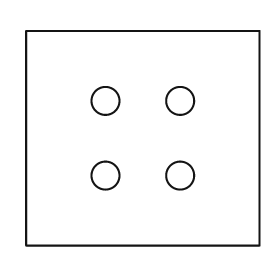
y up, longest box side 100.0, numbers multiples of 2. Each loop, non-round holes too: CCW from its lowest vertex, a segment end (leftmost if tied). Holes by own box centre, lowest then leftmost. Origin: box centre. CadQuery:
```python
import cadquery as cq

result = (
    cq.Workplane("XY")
    .moveTo(-50.0, -46.0)
    .lineTo(50.0, -46.0)
    .lineTo(50.0, 46.0)
    .lineTo(-50.0, 46.0)
    .close()
    .moveTo(-16.0, -16.0)
    .circle(6.0)
    .moveTo(16.0, -16.0)
    .circle(6.0)
    .moveTo(-16.0, 16.0)
    .circle(6.0)
    .moveTo(16.0, 16.0)
    .circle(6.0)
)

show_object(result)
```